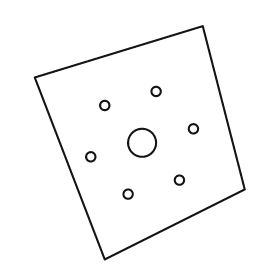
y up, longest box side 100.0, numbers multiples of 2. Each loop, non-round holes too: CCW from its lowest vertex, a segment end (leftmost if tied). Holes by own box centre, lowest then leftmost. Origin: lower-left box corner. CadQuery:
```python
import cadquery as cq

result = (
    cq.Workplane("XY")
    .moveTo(30.0, 0.0)
    .lineTo(90.0, 30.0)
    .lineTo(72.0, 100.0)
    .lineTo(0.0, 78.0)
    .close()
    .moveTo(40.0, 28.0)
    .circle(2.0)
    .moveTo(62.0, 34.0)
    .circle(2.0)
    .moveTo(24.0, 44.0)
    .circle(2.0)
    .moveTo(46.0, 50.0)
    .circle(6.0)
    .moveTo(68.0, 56.0)
    .circle(2.0)
    .moveTo(30.0, 66.0)
    .circle(2.0)
    .moveTo(52.0, 72.0)
    .circle(2.0)
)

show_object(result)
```